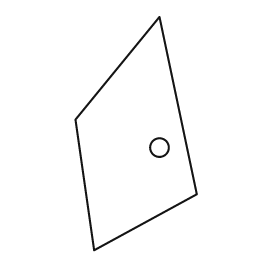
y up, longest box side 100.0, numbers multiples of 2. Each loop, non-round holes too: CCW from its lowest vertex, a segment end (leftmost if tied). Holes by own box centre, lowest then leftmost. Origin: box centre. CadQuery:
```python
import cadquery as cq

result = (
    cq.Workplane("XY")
    .moveTo(-18.0, -50.0)
    .lineTo(26.0, -26.0)
    .lineTo(10.0, 50.0)
    .lineTo(-26.0, 6.0)
    .close()
    .moveTo(10.0, -6.0)
    .circle(4.0)
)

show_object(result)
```